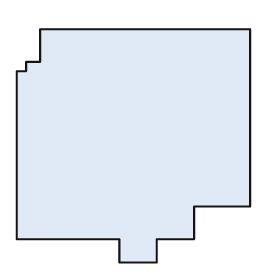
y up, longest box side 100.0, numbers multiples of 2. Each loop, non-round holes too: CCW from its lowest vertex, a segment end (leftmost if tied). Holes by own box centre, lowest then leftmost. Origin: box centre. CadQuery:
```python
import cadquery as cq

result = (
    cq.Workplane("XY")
    .moveTo(-6.0, -50.0)
    .lineTo(10.0, -50.0)
    .lineTo(10.0, -40.0)
    .lineTo(26.0, -40.0)
    .lineTo(26.0, -26.0)
    .lineTo(50.0, -26.0)
    .lineTo(50.0, 50.0)
    .lineTo(-40.0, 50.0)
    .lineTo(-40.0, 36.0)
    .lineTo(-46.0, 36.0)
    .lineTo(-46.0, 32.0)
    .lineTo(-50.0, 32.0)
    .lineTo(-50.0, -40.0)
    .lineTo(-6.0, -40.0)
    .close()
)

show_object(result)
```